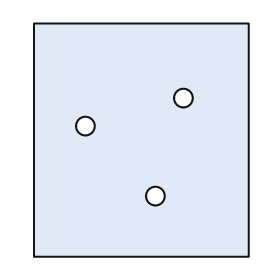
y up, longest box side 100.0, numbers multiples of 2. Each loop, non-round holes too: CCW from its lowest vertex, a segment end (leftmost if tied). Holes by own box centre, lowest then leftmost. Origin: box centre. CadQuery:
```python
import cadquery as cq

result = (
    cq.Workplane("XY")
    .moveTo(-46.0, -50.0)
    .lineTo(46.0, -50.0)
    .lineTo(46.0, 50.0)
    .lineTo(-46.0, 50.0)
    .close()
    .moveTo(6.0, -24.0)
    .circle(4.0)
    .moveTo(-24.0, 6.0)
    .circle(4.0)
    .moveTo(18.0, 18.0)
    .circle(4.0)
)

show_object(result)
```